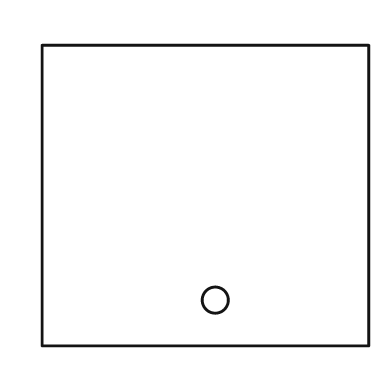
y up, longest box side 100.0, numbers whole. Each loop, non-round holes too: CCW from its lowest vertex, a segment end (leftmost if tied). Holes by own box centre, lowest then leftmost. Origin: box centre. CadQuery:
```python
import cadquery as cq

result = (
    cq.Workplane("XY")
    .moveTo(-50.0, -46.0)
    .lineTo(50.0, -46.0)
    .lineTo(50.0, 46.0)
    .lineTo(-50.0, 46.0)
    .close()
    .moveTo(3.0, -32.0)
    .circle(4.0)
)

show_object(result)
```